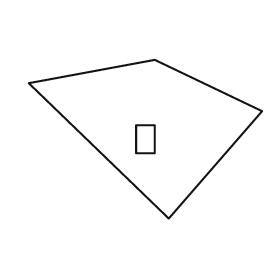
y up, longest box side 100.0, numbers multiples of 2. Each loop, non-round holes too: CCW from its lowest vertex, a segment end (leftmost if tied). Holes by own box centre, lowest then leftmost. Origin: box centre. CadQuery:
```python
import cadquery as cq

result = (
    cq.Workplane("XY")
    .moveTo(10.0, -34.0)
    .lineTo(50.0, 12.0)
    .lineTo(4.0, 34.0)
    .lineTo(-50.0, 24.0)
    .close()
    .moveTo(-4.0, -6.0)
    .lineTo(4.0, -6.0)
    .lineTo(4.0, 6.0)
    .lineTo(-4.0, 6.0)
    .close()
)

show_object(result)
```